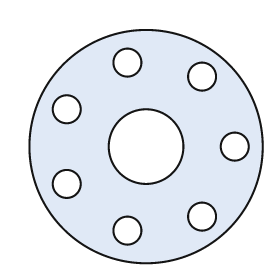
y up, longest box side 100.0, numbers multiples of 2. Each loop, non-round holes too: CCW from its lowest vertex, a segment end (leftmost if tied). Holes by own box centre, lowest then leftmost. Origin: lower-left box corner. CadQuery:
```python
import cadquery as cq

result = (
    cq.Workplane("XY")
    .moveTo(50.0, 50.0)
    .circle(50.0)
    .moveTo(42.0, 14.0)
    .circle(6.0)
    .moveTo(74.0, 20.0)
    .circle(6.0)
    .moveTo(16.0, 34.0)
    .circle(6.0)
    .moveTo(50.0, 50.0)
    .circle(16.0)
    .moveTo(88.0, 50.0)
    .circle(6.0)
    .moveTo(16.0, 66.0)
    .circle(6.0)
    .moveTo(74.0, 80.0)
    .circle(6.0)
    .moveTo(42.0, 86.0)
    .circle(6.0)
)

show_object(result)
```